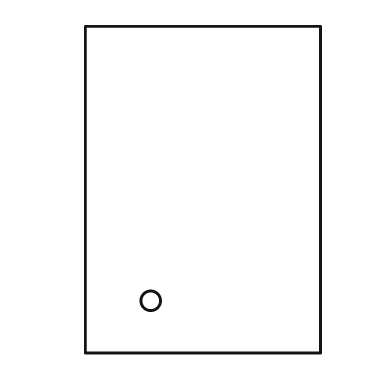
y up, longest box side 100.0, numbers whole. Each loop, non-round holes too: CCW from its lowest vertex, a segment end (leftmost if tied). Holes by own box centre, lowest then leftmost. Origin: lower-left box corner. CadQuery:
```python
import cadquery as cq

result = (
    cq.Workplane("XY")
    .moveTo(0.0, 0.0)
    .lineTo(72.0, 0.0)
    .lineTo(72.0, 100.0)
    .lineTo(0.0, 100.0)
    .close()
    .moveTo(20.0, 16.0)
    .circle(3.0)
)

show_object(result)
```